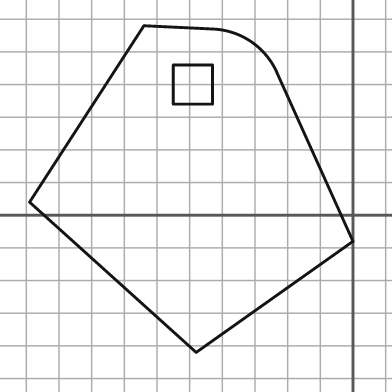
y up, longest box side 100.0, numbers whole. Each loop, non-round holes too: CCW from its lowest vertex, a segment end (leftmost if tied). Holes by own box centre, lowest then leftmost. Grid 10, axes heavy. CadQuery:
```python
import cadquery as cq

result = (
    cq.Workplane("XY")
    .moveTo(-48.0, -42.0)
    .lineTo(0.0, -8.0)
    .lineTo(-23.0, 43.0)
    .threePointArc((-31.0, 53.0), (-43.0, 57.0))
    .lineTo(-64.0, 58.0)
    .lineTo(-99.0, 4.0)
    .close()
    .moveTo(-55.0, 34.0)
    .lineTo(-43.0, 34.0)
    .lineTo(-43.0, 46.0)
    .lineTo(-55.0, 46.0)
    .close()
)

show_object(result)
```